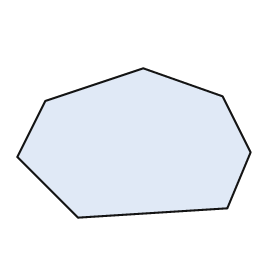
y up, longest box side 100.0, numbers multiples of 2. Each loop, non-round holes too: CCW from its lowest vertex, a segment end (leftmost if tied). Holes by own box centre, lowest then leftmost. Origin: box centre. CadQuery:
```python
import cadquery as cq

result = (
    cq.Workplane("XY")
    .moveTo(-24.0, -32.0)
    .lineTo(40.0, -28.0)
    .lineTo(50.0, -4.0)
    .lineTo(38.0, 20.0)
    .lineTo(4.0, 32.0)
    .lineTo(-38.0, 18.0)
    .lineTo(-50.0, -6.0)
    .close()
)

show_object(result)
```